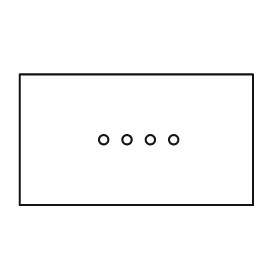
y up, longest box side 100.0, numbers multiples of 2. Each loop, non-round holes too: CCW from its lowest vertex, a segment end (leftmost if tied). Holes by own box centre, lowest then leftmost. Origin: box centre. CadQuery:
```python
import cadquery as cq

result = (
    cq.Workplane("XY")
    .moveTo(-50.0, -28.0)
    .lineTo(50.0, -28.0)
    .lineTo(50.0, 28.0)
    .lineTo(-50.0, 28.0)
    .close()
    .moveTo(-14.0, 0.0)
    .circle(2.0)
    .moveTo(-4.0, 0.0)
    .circle(2.0)
    .moveTo(6.0, 0.0)
    .circle(2.0)
    .moveTo(16.0, 0.0)
    .circle(2.0)
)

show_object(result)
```